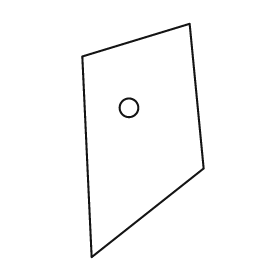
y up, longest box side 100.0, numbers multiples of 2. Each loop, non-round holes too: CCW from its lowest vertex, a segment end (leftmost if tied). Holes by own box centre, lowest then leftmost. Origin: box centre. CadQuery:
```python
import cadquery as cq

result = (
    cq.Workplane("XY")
    .moveTo(-22.0, -50.0)
    .lineTo(26.0, -12.0)
    .lineTo(20.0, 50.0)
    .lineTo(-26.0, 36.0)
    .close()
    .moveTo(-6.0, 14.0)
    .circle(4.0)
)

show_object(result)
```